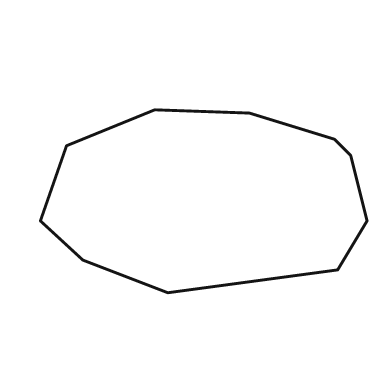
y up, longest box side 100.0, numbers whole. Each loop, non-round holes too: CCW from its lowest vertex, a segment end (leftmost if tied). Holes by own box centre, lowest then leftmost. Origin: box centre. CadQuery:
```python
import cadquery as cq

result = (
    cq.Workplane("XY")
    .moveTo(-11.0, -28.0)
    .lineTo(41.0, -21.0)
    .lineTo(50.0, -6.0)
    .lineTo(45.0, 14.0)
    .lineTo(40.0, 19.0)
    .lineTo(14.0, 27.0)
    .lineTo(-15.0, 28.0)
    .lineTo(-42.0, 17.0)
    .lineTo(-50.0, -6.0)
    .lineTo(-37.0, -18.0)
    .close()
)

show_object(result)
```